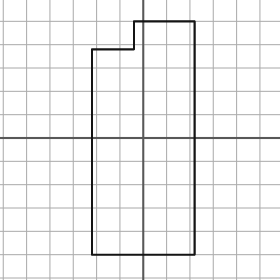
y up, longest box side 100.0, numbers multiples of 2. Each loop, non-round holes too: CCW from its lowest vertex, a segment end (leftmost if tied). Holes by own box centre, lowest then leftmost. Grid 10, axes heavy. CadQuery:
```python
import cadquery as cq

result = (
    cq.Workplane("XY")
    .moveTo(-22.0, -50.0)
    .lineTo(22.0, -50.0)
    .lineTo(22.0, 50.0)
    .lineTo(-4.0, 50.0)
    .lineTo(-4.0, 38.0)
    .lineTo(-22.0, 38.0)
    .close()
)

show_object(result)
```